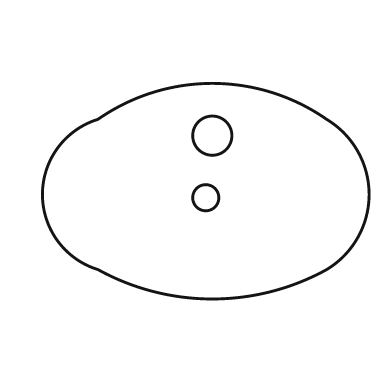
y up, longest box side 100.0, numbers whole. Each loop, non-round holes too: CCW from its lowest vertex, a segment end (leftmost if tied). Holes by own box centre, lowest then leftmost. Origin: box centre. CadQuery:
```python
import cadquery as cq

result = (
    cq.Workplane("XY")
    .moveTo(-33.0, -24.0)
    .threePointArc((2.0, -33.0), (37.0, -24.0))
    .threePointArc((50.0, -1.0), (37.0, 22.0))
    .threePointArc((2.0, 33.0), (-33.0, 22.0))
    .threePointArc((-50.0, -1.0), (-33.0, -24.0))
    .close()
    .moveTo(0.0, -2.0)
    .circle(4.0)
    .moveTo(2.0, 17.0)
    .circle(6.0)
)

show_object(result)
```